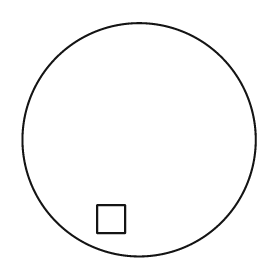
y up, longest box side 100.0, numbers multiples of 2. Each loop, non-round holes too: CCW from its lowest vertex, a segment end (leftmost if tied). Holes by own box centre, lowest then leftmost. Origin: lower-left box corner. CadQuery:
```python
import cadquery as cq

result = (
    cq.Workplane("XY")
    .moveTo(50.0, 50.0)
    .circle(50.0)
    .moveTo(32.0, 10.0)
    .lineTo(44.0, 10.0)
    .lineTo(44.0, 22.0)
    .lineTo(32.0, 22.0)
    .close()
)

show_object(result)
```